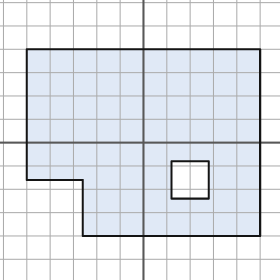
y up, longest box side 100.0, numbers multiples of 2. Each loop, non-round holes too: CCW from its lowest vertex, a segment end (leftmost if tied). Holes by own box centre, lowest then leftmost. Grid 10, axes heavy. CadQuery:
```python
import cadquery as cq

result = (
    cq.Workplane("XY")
    .moveTo(-26.0, -40.0)
    .lineTo(50.0, -40.0)
    .lineTo(50.0, 40.0)
    .lineTo(-50.0, 40.0)
    .lineTo(-50.0, -16.0)
    .lineTo(-26.0, -16.0)
    .close()
    .moveTo(12.0, -24.0)
    .lineTo(28.0, -24.0)
    .lineTo(28.0, -8.0)
    .lineTo(12.0, -8.0)
    .close()
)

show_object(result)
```